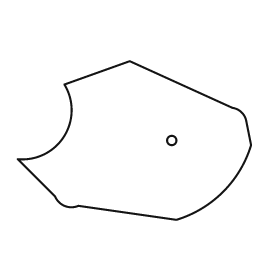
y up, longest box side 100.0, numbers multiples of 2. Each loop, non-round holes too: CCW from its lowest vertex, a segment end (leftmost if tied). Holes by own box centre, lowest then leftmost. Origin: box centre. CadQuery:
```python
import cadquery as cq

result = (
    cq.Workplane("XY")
    .moveTo(18.0, -34.0)
    .threePointArc((38.0, -22.0), (50.0, -2.0))
    .lineTo(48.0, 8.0)
    .threePointArc((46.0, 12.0), (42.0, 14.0))
    .lineTo(-2.0, 34.0)
    .lineTo(-30.0, 24.0)
    .threePointArc((-30.0, 2.0), (-50.0, -8.0))
    .lineTo(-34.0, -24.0)
    .threePointArc((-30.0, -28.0), (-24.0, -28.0))
    .close()
    .moveTo(16.0, 0.0)
    .circle(2.0)
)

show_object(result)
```